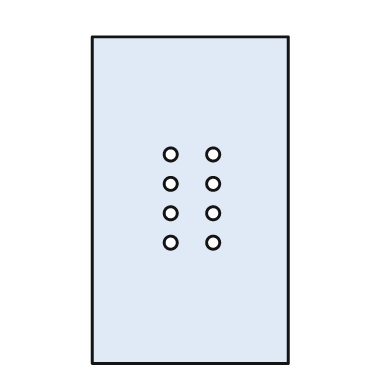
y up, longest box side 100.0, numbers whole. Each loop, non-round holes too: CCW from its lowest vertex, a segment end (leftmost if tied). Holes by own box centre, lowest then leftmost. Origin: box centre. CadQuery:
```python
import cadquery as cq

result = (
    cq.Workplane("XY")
    .moveTo(-30.0, -50.0)
    .lineTo(30.0, -50.0)
    .lineTo(30.0, 50.0)
    .lineTo(-30.0, 50.0)
    .close()
    .moveTo(-6.0, -13.0)
    .circle(2.0)
    .moveTo(7.0, -13.0)
    .circle(2.0)
    .moveTo(-6.0, -4.0)
    .circle(2.0)
    .moveTo(7.0, -4.0)
    .circle(2.0)
    .moveTo(-6.0, 5.0)
    .circle(2.0)
    .moveTo(7.0, 5.0)
    .circle(2.0)
    .moveTo(-6.0, 14.0)
    .circle(2.0)
    .moveTo(7.0, 14.0)
    .circle(2.0)
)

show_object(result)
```